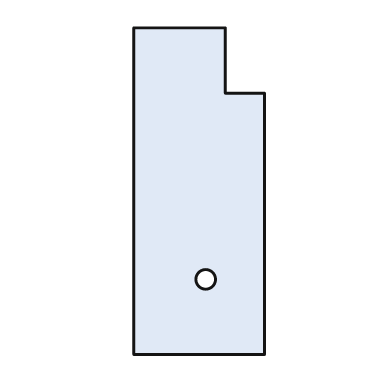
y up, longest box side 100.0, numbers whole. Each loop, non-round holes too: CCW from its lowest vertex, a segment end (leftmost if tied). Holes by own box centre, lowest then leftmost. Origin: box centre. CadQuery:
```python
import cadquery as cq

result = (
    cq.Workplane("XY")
    .moveTo(-20.0, -50.0)
    .lineTo(20.0, -50.0)
    .lineTo(20.0, 30.0)
    .lineTo(8.0, 30.0)
    .lineTo(8.0, 50.0)
    .lineTo(-20.0, 50.0)
    .close()
    .moveTo(2.0, -27.0)
    .circle(3.0)
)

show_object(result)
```